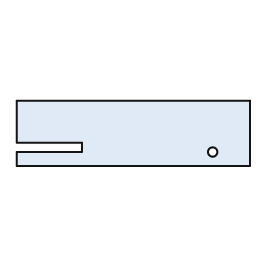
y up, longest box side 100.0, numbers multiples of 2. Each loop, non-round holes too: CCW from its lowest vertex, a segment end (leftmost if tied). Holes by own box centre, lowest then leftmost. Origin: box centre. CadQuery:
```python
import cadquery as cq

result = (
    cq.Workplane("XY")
    .moveTo(-50.0, -14.0)
    .lineTo(50.0, -14.0)
    .lineTo(50.0, 14.0)
    .lineTo(-50.0, 14.0)
    .lineTo(-50.0, -4.0)
    .lineTo(-22.0, -4.0)
    .lineTo(-22.0, -8.0)
    .lineTo(-50.0, -8.0)
    .close()
    .moveTo(34.0, -8.0)
    .circle(2.0)
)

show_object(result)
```